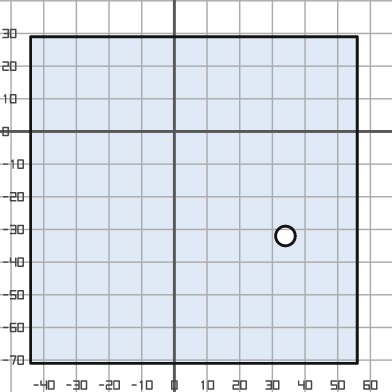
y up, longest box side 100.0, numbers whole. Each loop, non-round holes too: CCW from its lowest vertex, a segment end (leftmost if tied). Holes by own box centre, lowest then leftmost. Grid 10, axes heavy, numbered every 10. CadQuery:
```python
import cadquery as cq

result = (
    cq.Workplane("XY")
    .moveTo(-44.0, -71.0)
    .lineTo(56.0, -71.0)
    .lineTo(56.0, 29.0)
    .lineTo(-44.0, 29.0)
    .close()
    .moveTo(34.0, -32.0)
    .circle(3.0)
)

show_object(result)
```